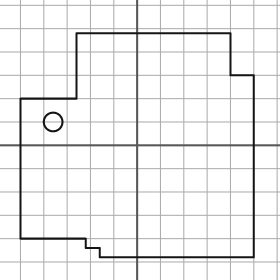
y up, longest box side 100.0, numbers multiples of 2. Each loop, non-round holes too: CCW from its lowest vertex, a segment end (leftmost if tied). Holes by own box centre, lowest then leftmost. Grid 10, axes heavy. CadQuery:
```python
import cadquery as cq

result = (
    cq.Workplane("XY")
    .moveTo(-16.0, -48.0)
    .lineTo(50.0, -48.0)
    .lineTo(50.0, 30.0)
    .lineTo(40.0, 30.0)
    .lineTo(40.0, 48.0)
    .lineTo(-26.0, 48.0)
    .lineTo(-26.0, 20.0)
    .lineTo(-50.0, 20.0)
    .lineTo(-50.0, -40.0)
    .lineTo(-22.0, -40.0)
    .lineTo(-22.0, -44.0)
    .lineTo(-16.0, -44.0)
    .close()
    .moveTo(-36.0, 10.0)
    .circle(4.0)
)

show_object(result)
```